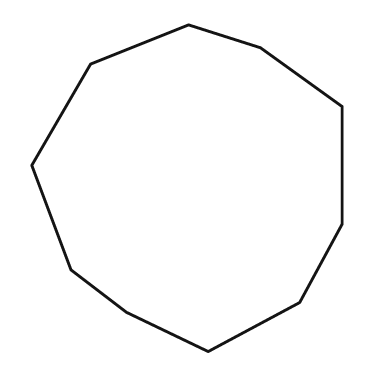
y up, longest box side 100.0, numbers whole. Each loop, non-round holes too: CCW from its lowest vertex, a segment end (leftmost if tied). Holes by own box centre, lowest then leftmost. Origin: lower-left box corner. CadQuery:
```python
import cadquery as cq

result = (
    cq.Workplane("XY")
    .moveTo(54.0, 0.0)
    .lineTo(82.0, 15.0)
    .lineTo(95.0, 39.0)
    .lineTo(95.0, 75.0)
    .lineTo(70.0, 93.0)
    .lineTo(48.0, 100.0)
    .lineTo(18.0, 88.0)
    .lineTo(0.0, 57.0)
    .lineTo(12.0, 25.0)
    .lineTo(29.0, 12.0)
    .close()
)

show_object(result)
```